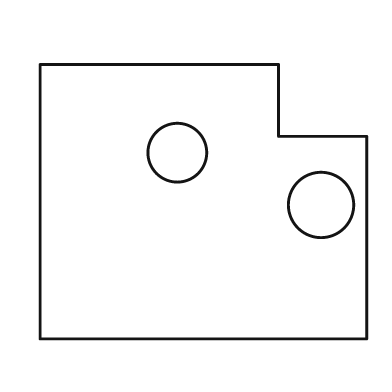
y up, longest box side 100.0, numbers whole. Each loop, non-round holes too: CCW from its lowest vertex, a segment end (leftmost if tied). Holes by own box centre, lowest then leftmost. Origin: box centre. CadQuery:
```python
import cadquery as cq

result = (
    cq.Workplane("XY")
    .moveTo(-50.0, -42.0)
    .lineTo(50.0, -42.0)
    .lineTo(50.0, 20.0)
    .lineTo(23.0, 20.0)
    .lineTo(23.0, 42.0)
    .lineTo(-50.0, 42.0)
    .close()
    .moveTo(36.0, -1.0)
    .circle(10.0)
    .moveTo(-8.0, 15.0)
    .circle(9.0)
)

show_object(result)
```